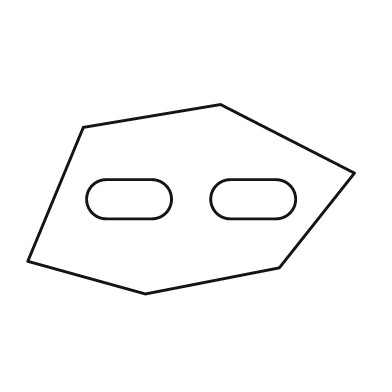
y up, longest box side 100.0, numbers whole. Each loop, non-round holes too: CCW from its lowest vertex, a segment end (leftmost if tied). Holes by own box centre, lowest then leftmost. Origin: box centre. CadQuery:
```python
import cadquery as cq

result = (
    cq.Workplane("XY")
    .moveTo(-14.0, -29.0)
    .lineTo(27.0, -21.0)
    .lineTo(50.0, 8.0)
    .lineTo(9.0, 29.0)
    .lineTo(-33.0, 22.0)
    .lineTo(-50.0, -19.0)
    .close()
    .moveTo(-26.0, -6.0)
    .lineTo(-12.0, -6.0)
    .threePointArc((-6.0, 0.0), (-12.0, 6.0))
    .lineTo(-26.0, 6.0)
    .threePointArc((-32.0, 0.0), (-26.0, -6.0))
    .close()
    .moveTo(12.0, -6.0)
    .lineTo(26.0, -6.0)
    .threePointArc((32.0, 0.0), (26.0, 6.0))
    .lineTo(12.0, 6.0)
    .threePointArc((6.0, 0.0), (12.0, -6.0))
    .close()
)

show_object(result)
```